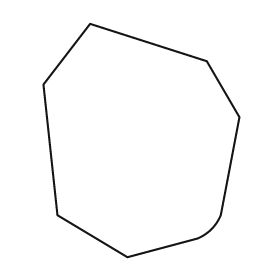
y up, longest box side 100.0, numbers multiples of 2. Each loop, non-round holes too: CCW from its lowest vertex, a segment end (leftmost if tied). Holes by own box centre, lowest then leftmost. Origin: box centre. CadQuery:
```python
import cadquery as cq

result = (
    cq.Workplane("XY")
    .moveTo(-6.0, -50.0)
    .lineTo(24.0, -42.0)
    .threePointArc((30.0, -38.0), (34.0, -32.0))
    .lineTo(42.0, 10.0)
    .lineTo(28.0, 34.0)
    .lineTo(-22.0, 50.0)
    .lineTo(-42.0, 24.0)
    .lineTo(-36.0, -32.0)
    .close()
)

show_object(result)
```